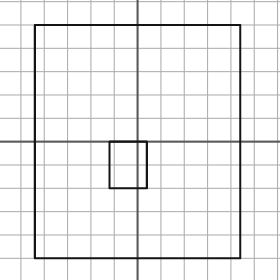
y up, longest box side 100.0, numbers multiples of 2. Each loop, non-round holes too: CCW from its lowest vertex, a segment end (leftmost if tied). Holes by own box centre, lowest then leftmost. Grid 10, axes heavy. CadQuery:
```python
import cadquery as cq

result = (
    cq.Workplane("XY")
    .moveTo(-44.0, -50.0)
    .lineTo(44.0, -50.0)
    .lineTo(44.0, 50.0)
    .lineTo(-44.0, 50.0)
    .close()
    .moveTo(-12.0, -20.0)
    .lineTo(4.0, -20.0)
    .lineTo(4.0, 0.0)
    .lineTo(-12.0, 0.0)
    .close()
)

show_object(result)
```